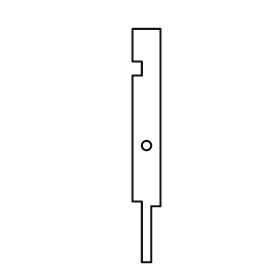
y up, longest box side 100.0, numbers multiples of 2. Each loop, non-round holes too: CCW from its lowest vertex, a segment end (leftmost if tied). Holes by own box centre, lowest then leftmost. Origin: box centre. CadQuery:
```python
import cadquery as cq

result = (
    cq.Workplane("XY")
    .moveTo(-2.0, -50.0)
    .lineTo(2.0, -50.0)
    .lineTo(2.0, -26.0)
    .lineTo(6.0, -26.0)
    .lineTo(6.0, 50.0)
    .lineTo(-6.0, 50.0)
    .lineTo(-6.0, 36.0)
    .lineTo(-2.0, 36.0)
    .lineTo(-2.0, 30.0)
    .lineTo(-6.0, 30.0)
    .lineTo(-6.0, -24.0)
    .lineTo(-2.0, -24.0)
    .close()
    .moveTo(0.0, 0.0)
    .circle(2.0)
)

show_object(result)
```